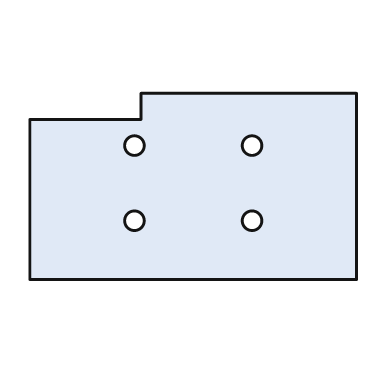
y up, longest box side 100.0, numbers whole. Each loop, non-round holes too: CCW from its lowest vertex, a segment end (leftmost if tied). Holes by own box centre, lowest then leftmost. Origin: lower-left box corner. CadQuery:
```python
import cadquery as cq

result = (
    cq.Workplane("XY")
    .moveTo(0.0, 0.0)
    .lineTo(100.0, 0.0)
    .lineTo(100.0, 57.0)
    .lineTo(34.0, 57.0)
    .lineTo(34.0, 49.0)
    .lineTo(0.0, 49.0)
    .close()
    .moveTo(32.0, 18.0)
    .circle(3.0)
    .moveTo(68.0, 18.0)
    .circle(3.0)
    .moveTo(32.0, 41.0)
    .circle(3.0)
    .moveTo(68.0, 41.0)
    .circle(3.0)
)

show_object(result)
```